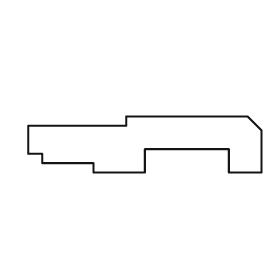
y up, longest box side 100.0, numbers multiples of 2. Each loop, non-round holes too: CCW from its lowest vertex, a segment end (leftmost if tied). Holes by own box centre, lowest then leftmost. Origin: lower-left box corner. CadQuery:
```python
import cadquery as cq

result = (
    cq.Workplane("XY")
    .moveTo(28.0, 0.0)
    .lineTo(50.0, 0.0)
    .lineTo(50.0, 10.0)
    .lineTo(86.0, 10.0)
    .lineTo(86.0, 0.0)
    .lineTo(100.0, 0.0)
    .lineTo(100.0, 18.0)
    .lineTo(94.0, 24.0)
    .lineTo(42.0, 24.0)
    .lineTo(42.0, 20.0)
    .lineTo(0.0, 20.0)
    .lineTo(0.0, 8.0)
    .lineTo(6.0, 8.0)
    .lineTo(6.0, 4.0)
    .lineTo(28.0, 4.0)
    .close()
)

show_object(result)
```